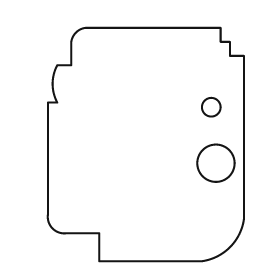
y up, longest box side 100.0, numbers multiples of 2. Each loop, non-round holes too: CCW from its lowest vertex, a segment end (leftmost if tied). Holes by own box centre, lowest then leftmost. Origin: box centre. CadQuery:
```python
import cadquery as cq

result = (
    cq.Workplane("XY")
    .moveTo(-20.0, -50.0)
    .lineTo(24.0, -50.0)
    .threePointArc((36.0, -44.0), (42.0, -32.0))
    .lineTo(42.0, 38.0)
    .lineTo(36.0, 38.0)
    .lineTo(36.0, 44.0)
    .lineTo(32.0, 44.0)
    .lineTo(32.0, 50.0)
    .lineTo(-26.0, 50.0)
    .threePointArc((-30.0, 48.0), (-32.0, 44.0))
    .lineTo(-32.0, 34.0)
    .lineTo(-38.0, 34.0)
    .threePointArc((-40.0, 26.0), (-38.0, 18.0))
    .lineTo(-42.0, 18.0)
    .lineTo(-42.0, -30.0)
    .threePointArc((-40.0, -36.0), (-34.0, -38.0))
    .lineTo(-20.0, -38.0)
    .close()
    .moveTo(30.0, -8.0)
    .circle(8.0)
    .moveTo(28.0, 16.0)
    .circle(4.0)
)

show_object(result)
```